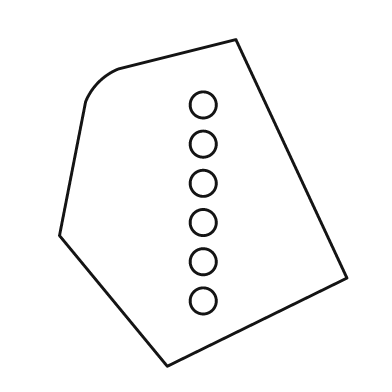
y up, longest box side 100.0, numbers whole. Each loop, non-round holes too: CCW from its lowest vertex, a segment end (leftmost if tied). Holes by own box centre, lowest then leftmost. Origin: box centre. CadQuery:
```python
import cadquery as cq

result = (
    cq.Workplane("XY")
    .moveTo(-11.0, -50.0)
    .lineTo(44.0, -23.0)
    .lineTo(10.0, 50.0)
    .lineTo(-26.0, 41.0)
    .threePointArc((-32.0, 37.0), (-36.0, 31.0))
    .lineTo(-44.0, -10.0)
    .close()
    .moveTo(0.0, -30.0)
    .circle(4.0)
    .moveTo(0.0, -18.0)
    .circle(4.0)
    .moveTo(0.0, -6.0)
    .circle(4.0)
    .moveTo(0.0, 6.0)
    .circle(4.0)
    .moveTo(0.0, 18.0)
    .circle(4.0)
    .moveTo(0.0, 30.0)
    .circle(4.0)
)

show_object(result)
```